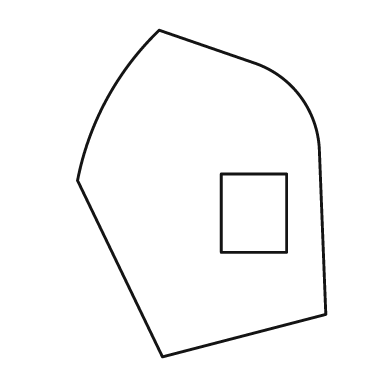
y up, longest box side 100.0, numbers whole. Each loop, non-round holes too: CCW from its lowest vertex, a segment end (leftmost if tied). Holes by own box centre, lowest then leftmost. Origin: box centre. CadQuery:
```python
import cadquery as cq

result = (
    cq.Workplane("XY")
    .moveTo(-12.0, -50.0)
    .lineTo(38.0, -37.0)
    .lineTo(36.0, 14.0)
    .threePointArc((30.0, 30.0), (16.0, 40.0))
    .lineTo(-13.0, 50.0)
    .threePointArc((-29.0, 29.0), (-38.0, 4.0))
    .close()
    .moveTo(6.0, -18.0)
    .lineTo(26.0, -18.0)
    .lineTo(26.0, 6.0)
    .lineTo(6.0, 6.0)
    .close()
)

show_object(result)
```